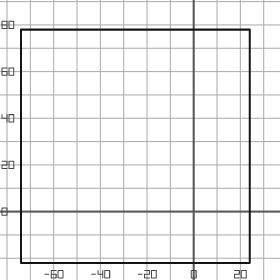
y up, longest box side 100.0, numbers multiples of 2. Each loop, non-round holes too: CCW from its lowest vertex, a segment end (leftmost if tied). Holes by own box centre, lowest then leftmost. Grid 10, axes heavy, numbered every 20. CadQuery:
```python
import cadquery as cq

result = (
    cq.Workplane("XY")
    .moveTo(-74.0, -22.0)
    .lineTo(24.0, -22.0)
    .lineTo(24.0, 78.0)
    .lineTo(-74.0, 78.0)
    .close()
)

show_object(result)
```